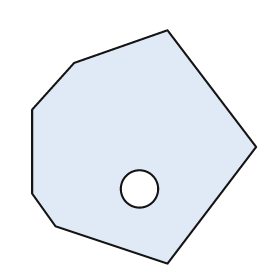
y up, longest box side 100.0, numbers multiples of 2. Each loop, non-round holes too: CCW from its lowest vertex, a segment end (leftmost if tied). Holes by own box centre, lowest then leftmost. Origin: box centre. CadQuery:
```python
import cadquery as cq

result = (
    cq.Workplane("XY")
    .moveTo(10.0, -50.0)
    .lineTo(48.0, 0.0)
    .lineTo(10.0, 50.0)
    .lineTo(-30.0, 36.0)
    .lineTo(-48.0, 16.0)
    .lineTo(-48.0, -20.0)
    .lineTo(-38.0, -34.0)
    .close()
    .moveTo(-2.0, -18.0)
    .circle(8.0)
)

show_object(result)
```